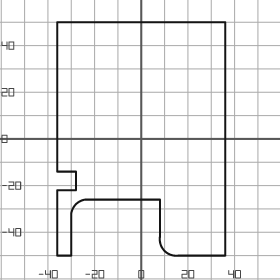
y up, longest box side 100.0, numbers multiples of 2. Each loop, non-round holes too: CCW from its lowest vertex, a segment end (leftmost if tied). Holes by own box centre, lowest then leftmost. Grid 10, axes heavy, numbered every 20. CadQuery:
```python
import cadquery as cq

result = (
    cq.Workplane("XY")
    .moveTo(-36.0, -50.0)
    .lineTo(-30.0, -50.0)
    .lineTo(-30.0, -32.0)
    .threePointArc((-28.0, -28.0), (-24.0, -26.0))
    .lineTo(8.0, -26.0)
    .lineTo(8.0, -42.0)
    .threePointArc((10.0, -48.0), (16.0, -50.0))
    .lineTo(36.0, -50.0)
    .lineTo(36.0, 50.0)
    .lineTo(-36.0, 50.0)
    .lineTo(-36.0, -14.0)
    .lineTo(-28.0, -14.0)
    .lineTo(-28.0, -22.0)
    .lineTo(-36.0, -22.0)
    .close()
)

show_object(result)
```